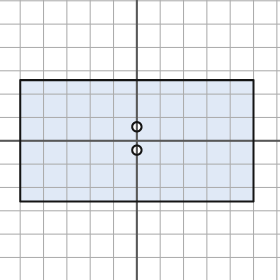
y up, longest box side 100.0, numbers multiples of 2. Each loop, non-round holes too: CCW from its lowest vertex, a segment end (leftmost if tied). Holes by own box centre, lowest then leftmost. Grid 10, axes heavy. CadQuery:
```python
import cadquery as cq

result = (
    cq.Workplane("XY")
    .moveTo(-50.0, -26.0)
    .lineTo(50.0, -26.0)
    .lineTo(50.0, 26.0)
    .lineTo(-50.0, 26.0)
    .close()
    .moveTo(0.0, -4.0)
    .circle(2.0)
    .moveTo(0.0, 6.0)
    .circle(2.0)
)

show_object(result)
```